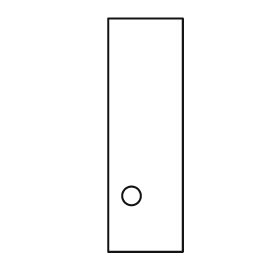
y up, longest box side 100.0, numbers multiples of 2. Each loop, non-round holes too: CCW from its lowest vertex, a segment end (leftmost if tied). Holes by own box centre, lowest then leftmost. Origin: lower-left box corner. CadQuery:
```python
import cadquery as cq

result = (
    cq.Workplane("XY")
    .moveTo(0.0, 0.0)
    .lineTo(32.0, 0.0)
    .lineTo(32.0, 100.0)
    .lineTo(0.0, 100.0)
    .close()
    .moveTo(10.0, 24.0)
    .circle(4.0)
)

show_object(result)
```